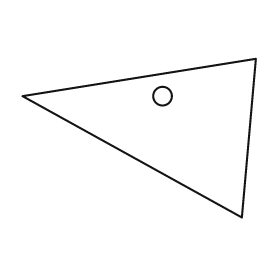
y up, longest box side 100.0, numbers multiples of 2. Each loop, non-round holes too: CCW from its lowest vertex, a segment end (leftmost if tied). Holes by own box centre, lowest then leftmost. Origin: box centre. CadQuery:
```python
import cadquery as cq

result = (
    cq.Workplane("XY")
    .moveTo(44.0, -34.0)
    .lineTo(50.0, 34.0)
    .lineTo(-50.0, 18.0)
    .close()
    .moveTo(10.0, 18.0)
    .circle(4.0)
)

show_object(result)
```